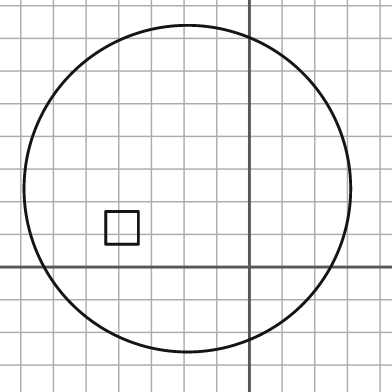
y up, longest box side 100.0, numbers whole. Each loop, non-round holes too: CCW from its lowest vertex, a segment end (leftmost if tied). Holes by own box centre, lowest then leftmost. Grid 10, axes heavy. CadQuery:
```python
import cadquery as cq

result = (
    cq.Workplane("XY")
    .moveTo(-19.0, 24.0)
    .circle(50.0)
    .moveTo(-44.0, 7.0)
    .lineTo(-34.0, 7.0)
    .lineTo(-34.0, 17.0)
    .lineTo(-44.0, 17.0)
    .close()
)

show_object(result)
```